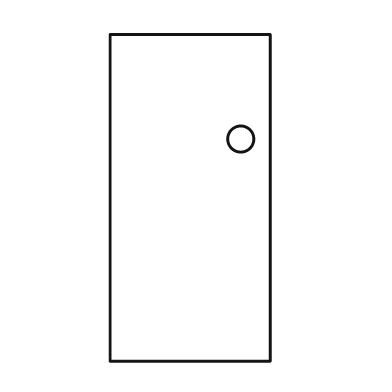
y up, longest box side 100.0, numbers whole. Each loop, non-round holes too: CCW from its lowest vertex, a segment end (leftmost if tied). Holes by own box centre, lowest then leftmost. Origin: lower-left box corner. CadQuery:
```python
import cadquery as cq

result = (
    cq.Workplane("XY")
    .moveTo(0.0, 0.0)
    .lineTo(49.0, 0.0)
    .lineTo(49.0, 100.0)
    .lineTo(0.0, 100.0)
    .close()
    .moveTo(40.0, 68.0)
    .circle(4.0)
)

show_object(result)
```